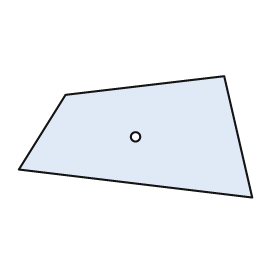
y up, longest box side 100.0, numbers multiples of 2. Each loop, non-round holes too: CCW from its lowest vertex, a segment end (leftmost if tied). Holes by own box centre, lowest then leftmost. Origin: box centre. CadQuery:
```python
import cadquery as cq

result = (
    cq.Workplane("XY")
    .moveTo(50.0, -26.0)
    .lineTo(38.0, 26.0)
    .lineTo(-30.0, 18.0)
    .lineTo(-50.0, -14.0)
    .close()
    .moveTo(0.0, 0.0)
    .circle(2.0)
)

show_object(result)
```